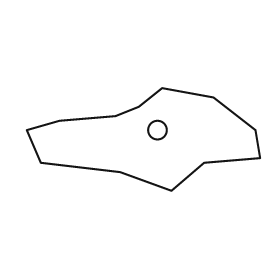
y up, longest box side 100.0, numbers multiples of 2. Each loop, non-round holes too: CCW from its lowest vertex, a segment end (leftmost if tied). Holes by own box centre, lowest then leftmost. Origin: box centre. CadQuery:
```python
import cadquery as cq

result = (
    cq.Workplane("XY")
    .moveTo(12.0, -22.0)
    .lineTo(26.0, -10.0)
    .lineTo(50.0, -8.0)
    .lineTo(48.0, 4.0)
    .lineTo(30.0, 18.0)
    .lineTo(8.0, 22.0)
    .lineTo(-2.0, 14.0)
    .lineTo(-12.0, 10.0)
    .lineTo(-36.0, 8.0)
    .lineTo(-50.0, 4.0)
    .lineTo(-44.0, -10.0)
    .lineTo(-10.0, -14.0)
    .close()
    .moveTo(6.0, 4.0)
    .circle(4.0)
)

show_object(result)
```